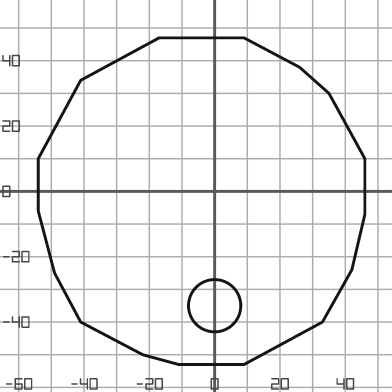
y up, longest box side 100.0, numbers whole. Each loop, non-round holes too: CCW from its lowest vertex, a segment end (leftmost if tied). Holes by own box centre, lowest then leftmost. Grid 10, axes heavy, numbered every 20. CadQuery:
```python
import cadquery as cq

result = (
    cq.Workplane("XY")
    .moveTo(-11.0, -53.0)
    .lineTo(9.0, -53.0)
    .lineTo(33.0, -40.0)
    .lineTo(42.0, -24.0)
    .lineTo(46.0, -7.0)
    .lineTo(46.0, 10.0)
    .lineTo(35.0, 30.0)
    .lineTo(26.0, 38.0)
    .lineTo(9.0, 47.0)
    .lineTo(-17.0, 47.0)
    .lineTo(-41.0, 34.0)
    .lineTo(-54.0, 10.0)
    .lineTo(-54.0, -6.0)
    .lineTo(-49.0, -25.0)
    .lineTo(-41.0, -40.0)
    .lineTo(-22.0, -50.0)
    .close()
    .moveTo(0.0, -35.0)
    .circle(8.0)
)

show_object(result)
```